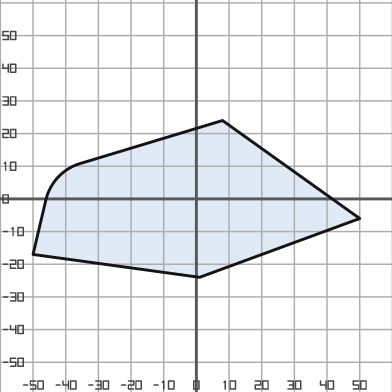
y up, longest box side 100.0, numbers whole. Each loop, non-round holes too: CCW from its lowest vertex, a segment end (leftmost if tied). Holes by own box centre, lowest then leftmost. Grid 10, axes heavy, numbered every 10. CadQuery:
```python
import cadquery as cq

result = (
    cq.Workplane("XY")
    .moveTo(1.0, -24.0)
    .lineTo(50.0, -6.0)
    .lineTo(8.0, 24.0)
    .lineTo(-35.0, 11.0)
    .threePointArc((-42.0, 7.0), (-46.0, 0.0))
    .lineTo(-50.0, -17.0)
    .close()
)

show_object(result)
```